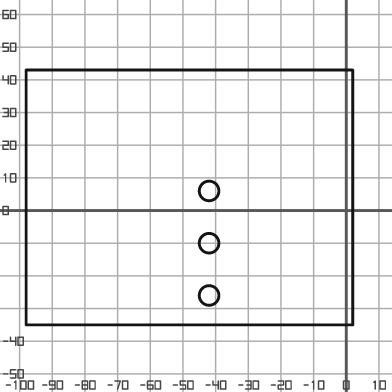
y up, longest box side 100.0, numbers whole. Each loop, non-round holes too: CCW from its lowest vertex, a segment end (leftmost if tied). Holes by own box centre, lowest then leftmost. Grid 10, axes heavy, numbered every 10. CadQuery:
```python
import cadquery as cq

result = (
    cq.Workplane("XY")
    .moveTo(-98.0, -35.0)
    .lineTo(2.0, -35.0)
    .lineTo(2.0, 43.0)
    .lineTo(-98.0, 43.0)
    .close()
    .moveTo(-42.0, -26.0)
    .circle(3.0)
    .moveTo(-42.0, -10.0)
    .circle(3.0)
    .moveTo(-42.0, 6.0)
    .circle(3.0)
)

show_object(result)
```